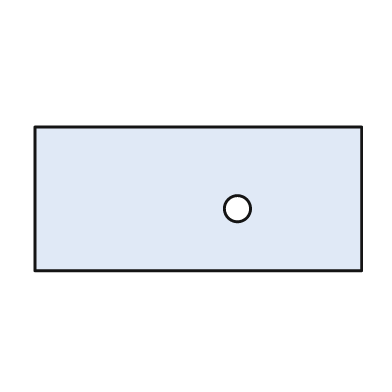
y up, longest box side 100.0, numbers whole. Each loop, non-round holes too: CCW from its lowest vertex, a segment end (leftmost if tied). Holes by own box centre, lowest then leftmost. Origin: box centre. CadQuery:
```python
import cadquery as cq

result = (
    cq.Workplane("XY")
    .moveTo(-50.0, -22.0)
    .lineTo(50.0, -22.0)
    .lineTo(50.0, 22.0)
    .lineTo(-50.0, 22.0)
    .close()
    .moveTo(12.0, -3.0)
    .circle(4.0)
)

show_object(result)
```